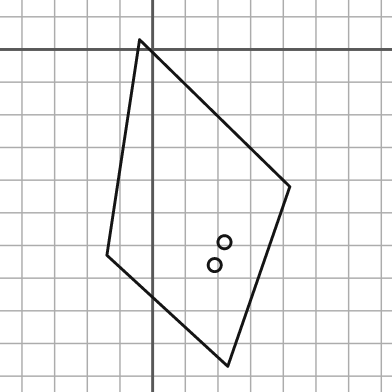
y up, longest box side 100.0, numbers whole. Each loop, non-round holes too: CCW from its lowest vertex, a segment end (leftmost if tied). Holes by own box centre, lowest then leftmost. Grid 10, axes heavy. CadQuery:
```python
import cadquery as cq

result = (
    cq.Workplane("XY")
    .moveTo(23.0, -97.0)
    .lineTo(42.0, -42.0)
    .lineTo(-4.0, 3.0)
    .lineTo(-14.0, -63.0)
    .close()
    .moveTo(19.0, -66.0)
    .circle(2.0)
    .moveTo(22.0, -59.0)
    .circle(2.0)
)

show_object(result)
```